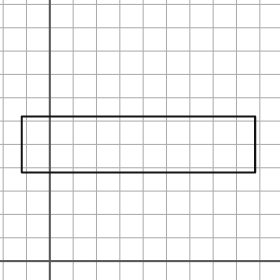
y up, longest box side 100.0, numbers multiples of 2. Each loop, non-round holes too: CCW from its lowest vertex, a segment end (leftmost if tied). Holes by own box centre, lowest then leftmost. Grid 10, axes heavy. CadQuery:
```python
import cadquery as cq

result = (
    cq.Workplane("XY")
    .moveTo(-12.0, 38.0)
    .lineTo(88.0, 38.0)
    .lineTo(88.0, 62.0)
    .lineTo(-12.0, 62.0)
    .close()
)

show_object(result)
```